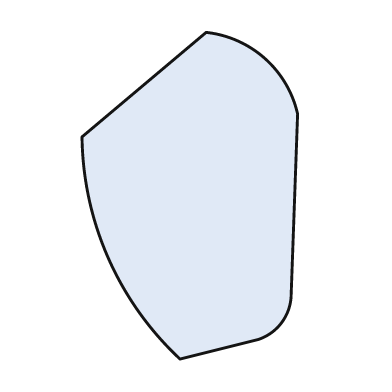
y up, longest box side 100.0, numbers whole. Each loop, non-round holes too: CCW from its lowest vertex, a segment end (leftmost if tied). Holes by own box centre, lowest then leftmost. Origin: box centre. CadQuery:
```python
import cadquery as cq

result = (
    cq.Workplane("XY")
    .moveTo(-3.0, -50.0)
    .lineTo(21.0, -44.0)
    .threePointArc((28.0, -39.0), (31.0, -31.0))
    .lineTo(33.0, 25.0)
    .threePointArc((23.0, 42.0), (5.0, 50.0))
    .lineTo(-33.0, 18.0)
    .threePointArc((-25.0, -19.0), (-3.0, -50.0))
    .close()
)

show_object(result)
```